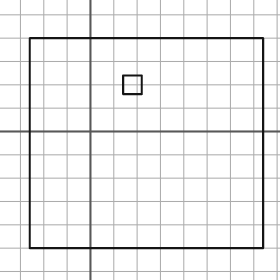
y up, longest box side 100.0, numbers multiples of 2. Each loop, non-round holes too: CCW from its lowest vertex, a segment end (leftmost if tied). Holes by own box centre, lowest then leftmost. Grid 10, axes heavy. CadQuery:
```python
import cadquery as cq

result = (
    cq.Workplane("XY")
    .moveTo(-26.0, -50.0)
    .lineTo(74.0, -50.0)
    .lineTo(74.0, 40.0)
    .lineTo(-26.0, 40.0)
    .close()
    .moveTo(14.0, 16.0)
    .lineTo(22.0, 16.0)
    .lineTo(22.0, 24.0)
    .lineTo(14.0, 24.0)
    .close()
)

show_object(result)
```